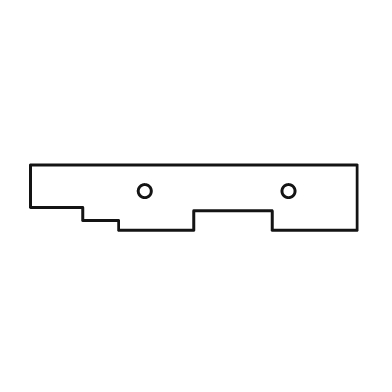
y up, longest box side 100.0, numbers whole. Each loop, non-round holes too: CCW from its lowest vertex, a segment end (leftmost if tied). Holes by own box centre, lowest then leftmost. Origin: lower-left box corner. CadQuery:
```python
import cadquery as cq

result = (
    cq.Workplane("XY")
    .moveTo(27.0, 0.0)
    .lineTo(50.0, 0.0)
    .lineTo(50.0, 6.0)
    .lineTo(74.0, 6.0)
    .lineTo(74.0, 0.0)
    .lineTo(100.0, 0.0)
    .lineTo(100.0, 20.0)
    .lineTo(0.0, 20.0)
    .lineTo(0.0, 7.0)
    .lineTo(16.0, 7.0)
    .lineTo(16.0, 3.0)
    .lineTo(27.0, 3.0)
    .close()
    .moveTo(35.0, 12.0)
    .circle(2.0)
    .moveTo(79.0, 12.0)
    .circle(2.0)
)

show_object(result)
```